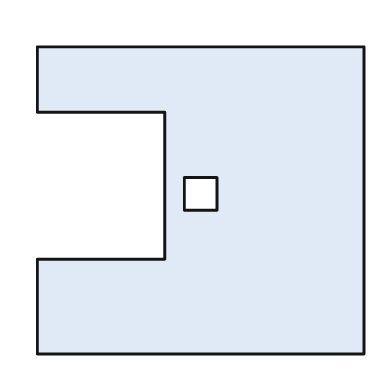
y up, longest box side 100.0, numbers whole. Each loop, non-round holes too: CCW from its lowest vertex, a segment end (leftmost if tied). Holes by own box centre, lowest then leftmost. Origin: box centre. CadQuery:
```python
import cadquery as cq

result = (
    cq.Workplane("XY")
    .moveTo(-50.0, -47.0)
    .lineTo(50.0, -47.0)
    .lineTo(50.0, 47.0)
    .lineTo(-50.0, 47.0)
    .lineTo(-50.0, 27.0)
    .lineTo(-11.0, 27.0)
    .lineTo(-11.0, -18.0)
    .lineTo(-50.0, -18.0)
    .close()
    .moveTo(-5.0, -3.0)
    .lineTo(5.0, -3.0)
    .lineTo(5.0, 7.0)
    .lineTo(-5.0, 7.0)
    .close()
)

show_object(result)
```